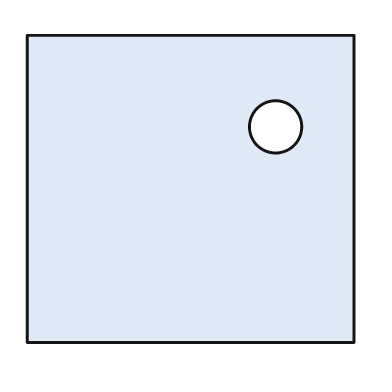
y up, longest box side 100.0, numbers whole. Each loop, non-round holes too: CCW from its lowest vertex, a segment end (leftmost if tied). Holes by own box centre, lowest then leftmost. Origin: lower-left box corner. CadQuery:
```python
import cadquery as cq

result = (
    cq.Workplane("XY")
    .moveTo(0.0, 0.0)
    .lineTo(100.0, 0.0)
    .lineTo(100.0, 94.0)
    .lineTo(0.0, 94.0)
    .close()
    .moveTo(76.0, 66.0)
    .circle(8.0)
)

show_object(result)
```